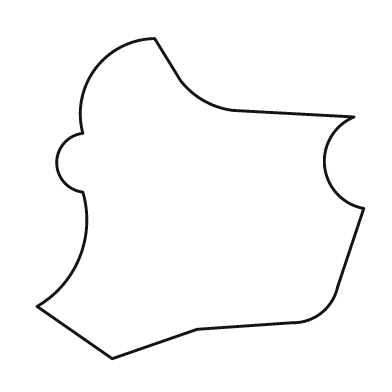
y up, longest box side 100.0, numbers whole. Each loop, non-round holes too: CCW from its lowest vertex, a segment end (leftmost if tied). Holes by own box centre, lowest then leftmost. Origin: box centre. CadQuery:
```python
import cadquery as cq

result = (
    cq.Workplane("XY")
    .moveTo(-27.0, -49.0)
    .lineTo(-1.0, -40.0)
    .lineTo(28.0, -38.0)
    .threePointArc((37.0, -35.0), (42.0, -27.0))
    .lineTo(50.0, -3.0)
    .threePointArc((38.0, 10.0), (47.0, 25.0))
    .lineTo(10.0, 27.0)
    .threePointArc((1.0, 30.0), (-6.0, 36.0))
    .lineTo(-14.0, 49.0)
    .threePointArc((-32.0, 40.0), (-36.0, 20.0))
    .threePointArc((-44.0, 11.0), (-36.0, 2.0))
    .threePointArc((-37.0, -18.0), (-50.0, -33.0))
    .close()
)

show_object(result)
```